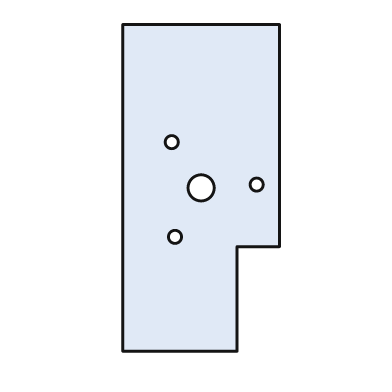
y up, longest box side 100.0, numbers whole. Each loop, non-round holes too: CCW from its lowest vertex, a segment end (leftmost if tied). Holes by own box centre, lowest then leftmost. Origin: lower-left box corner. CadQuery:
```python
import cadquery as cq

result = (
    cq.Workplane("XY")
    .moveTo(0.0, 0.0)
    .lineTo(35.0, 0.0)
    .lineTo(35.0, 32.0)
    .lineTo(48.0, 32.0)
    .lineTo(48.0, 100.0)
    .lineTo(0.0, 100.0)
    .close()
    .moveTo(16.0, 35.0)
    .circle(2.0)
    .moveTo(24.0, 50.0)
    .circle(4.0)
    .moveTo(41.0, 51.0)
    .circle(2.0)
    .moveTo(15.0, 64.0)
    .circle(2.0)
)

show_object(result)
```